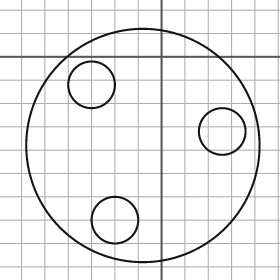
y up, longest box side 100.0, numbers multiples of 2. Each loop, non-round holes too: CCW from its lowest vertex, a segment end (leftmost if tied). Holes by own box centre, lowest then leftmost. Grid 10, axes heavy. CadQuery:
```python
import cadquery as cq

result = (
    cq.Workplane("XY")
    .moveTo(-8.0, -38.0)
    .circle(50.0)
    .moveTo(-20.0, -70.0)
    .circle(10.0)
    .moveTo(26.0, -32.0)
    .circle(10.0)
    .moveTo(-30.0, -12.0)
    .circle(10.0)
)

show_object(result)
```